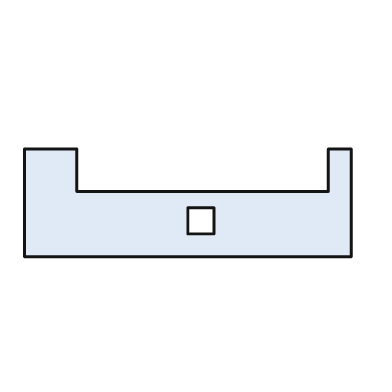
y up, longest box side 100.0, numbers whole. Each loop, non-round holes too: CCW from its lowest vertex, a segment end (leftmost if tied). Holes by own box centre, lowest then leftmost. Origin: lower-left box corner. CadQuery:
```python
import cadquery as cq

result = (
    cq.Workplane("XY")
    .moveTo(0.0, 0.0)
    .lineTo(100.0, 0.0)
    .lineTo(100.0, 33.0)
    .lineTo(93.0, 33.0)
    .lineTo(93.0, 20.0)
    .lineTo(16.0, 20.0)
    .lineTo(16.0, 33.0)
    .lineTo(0.0, 33.0)
    .close()
    .moveTo(50.0, 7.0)
    .lineTo(58.0, 7.0)
    .lineTo(58.0, 15.0)
    .lineTo(50.0, 15.0)
    .close()
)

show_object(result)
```